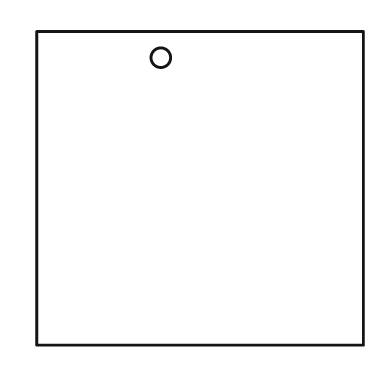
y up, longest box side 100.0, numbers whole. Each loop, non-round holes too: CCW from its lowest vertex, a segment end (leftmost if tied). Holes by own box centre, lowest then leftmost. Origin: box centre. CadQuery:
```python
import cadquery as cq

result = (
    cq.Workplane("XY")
    .moveTo(-50.0, -48.0)
    .lineTo(50.0, -48.0)
    .lineTo(50.0, 48.0)
    .lineTo(-50.0, 48.0)
    .close()
    .moveTo(-12.0, 40.0)
    .circle(3.0)
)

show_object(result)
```